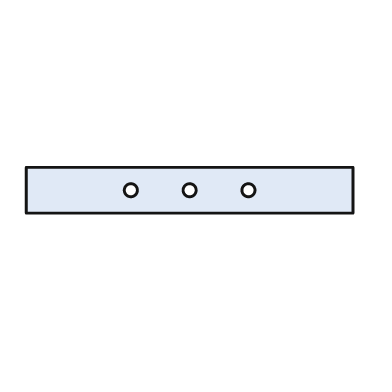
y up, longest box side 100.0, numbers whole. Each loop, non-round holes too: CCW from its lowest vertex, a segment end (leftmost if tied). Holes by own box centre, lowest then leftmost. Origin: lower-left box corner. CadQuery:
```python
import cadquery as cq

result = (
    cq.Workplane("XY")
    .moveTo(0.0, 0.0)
    .lineTo(100.0, 0.0)
    .lineTo(100.0, 14.0)
    .lineTo(0.0, 14.0)
    .close()
    .moveTo(32.0, 7.0)
    .circle(2.0)
    .moveTo(50.0, 7.0)
    .circle(2.0)
    .moveTo(68.0, 7.0)
    .circle(2.0)
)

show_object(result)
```